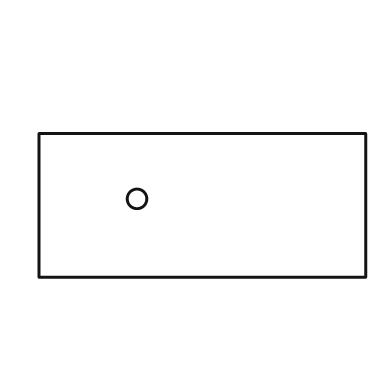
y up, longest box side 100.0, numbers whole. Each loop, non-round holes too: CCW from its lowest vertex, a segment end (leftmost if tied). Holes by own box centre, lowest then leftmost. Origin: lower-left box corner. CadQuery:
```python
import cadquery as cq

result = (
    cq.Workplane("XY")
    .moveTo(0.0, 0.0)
    .lineTo(100.0, 0.0)
    .lineTo(100.0, 44.0)
    .lineTo(0.0, 44.0)
    .close()
    .moveTo(30.0, 24.0)
    .circle(3.0)
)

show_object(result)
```